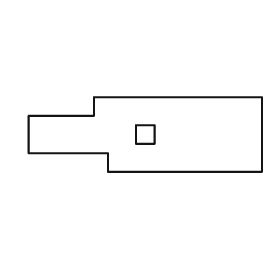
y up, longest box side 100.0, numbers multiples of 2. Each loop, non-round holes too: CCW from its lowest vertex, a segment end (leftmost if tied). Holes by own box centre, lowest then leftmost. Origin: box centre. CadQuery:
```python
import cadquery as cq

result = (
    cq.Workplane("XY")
    .moveTo(-16.0, -16.0)
    .lineTo(50.0, -16.0)
    .lineTo(50.0, 16.0)
    .lineTo(-22.0, 16.0)
    .lineTo(-22.0, 8.0)
    .lineTo(-50.0, 8.0)
    .lineTo(-50.0, -8.0)
    .lineTo(-16.0, -8.0)
    .close()
    .moveTo(-4.0, -4.0)
    .lineTo(4.0, -4.0)
    .lineTo(4.0, 4.0)
    .lineTo(-4.0, 4.0)
    .close()
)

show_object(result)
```